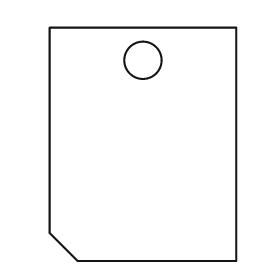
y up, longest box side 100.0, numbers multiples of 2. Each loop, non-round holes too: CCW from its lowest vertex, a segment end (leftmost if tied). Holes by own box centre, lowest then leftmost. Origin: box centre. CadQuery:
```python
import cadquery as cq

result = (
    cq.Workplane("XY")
    .moveTo(-28.0, -50.0)
    .lineTo(40.0, -50.0)
    .lineTo(40.0, 50.0)
    .lineTo(-40.0, 50.0)
    .lineTo(-40.0, -38.0)
    .close()
    .moveTo(0.0, 36.0)
    .circle(8.0)
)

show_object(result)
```